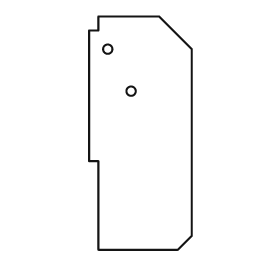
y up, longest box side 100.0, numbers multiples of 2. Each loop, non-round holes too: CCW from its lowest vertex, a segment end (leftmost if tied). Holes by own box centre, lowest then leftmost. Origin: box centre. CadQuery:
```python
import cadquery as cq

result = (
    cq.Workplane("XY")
    .moveTo(-18.0, -50.0)
    .lineTo(16.0, -50.0)
    .lineTo(22.0, -44.0)
    .lineTo(22.0, 36.0)
    .lineTo(8.0, 50.0)
    .lineTo(-18.0, 50.0)
    .lineTo(-18.0, 44.0)
    .lineTo(-22.0, 44.0)
    .lineTo(-22.0, -12.0)
    .lineTo(-18.0, -12.0)
    .close()
    .moveTo(-4.0, 18.0)
    .circle(2.0)
    .moveTo(-14.0, 36.0)
    .circle(2.0)
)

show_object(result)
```